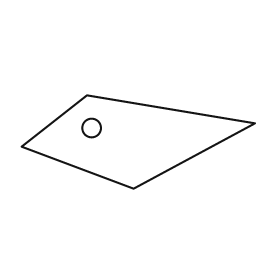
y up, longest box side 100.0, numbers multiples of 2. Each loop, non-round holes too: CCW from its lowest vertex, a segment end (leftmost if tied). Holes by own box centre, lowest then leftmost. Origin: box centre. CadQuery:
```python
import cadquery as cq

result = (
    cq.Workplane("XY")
    .moveTo(-2.0, -20.0)
    .lineTo(50.0, 8.0)
    .lineTo(-22.0, 20.0)
    .lineTo(-50.0, -2.0)
    .close()
    .moveTo(-20.0, 6.0)
    .circle(4.0)
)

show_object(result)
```